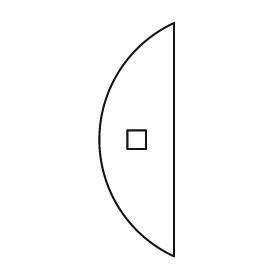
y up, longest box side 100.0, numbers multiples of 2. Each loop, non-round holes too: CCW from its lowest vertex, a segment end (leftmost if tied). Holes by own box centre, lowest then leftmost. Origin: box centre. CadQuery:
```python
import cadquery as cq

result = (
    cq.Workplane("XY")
    .moveTo(16.0, -50.0)
    .lineTo(16.0, 50.0)
    .threePointArc((-16.0, 0.0), (16.0, -50.0))
    .close()
    .moveTo(-4.0, -4.0)
    .lineTo(4.0, -4.0)
    .lineTo(4.0, 4.0)
    .lineTo(-4.0, 4.0)
    .close()
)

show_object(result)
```